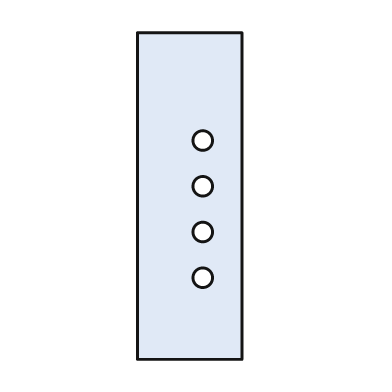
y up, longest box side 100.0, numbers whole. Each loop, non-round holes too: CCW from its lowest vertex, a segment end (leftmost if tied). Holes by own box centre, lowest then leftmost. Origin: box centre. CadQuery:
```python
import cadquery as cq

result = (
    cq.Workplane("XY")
    .moveTo(-16.0, -50.0)
    .lineTo(16.0, -50.0)
    .lineTo(16.0, 50.0)
    .lineTo(-16.0, 50.0)
    .close()
    .moveTo(4.0, -25.0)
    .circle(3.0)
    .moveTo(4.0, -11.0)
    .circle(3.0)
    .moveTo(4.0, 3.0)
    .circle(3.0)
    .moveTo(4.0, 17.0)
    .circle(3.0)
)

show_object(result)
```